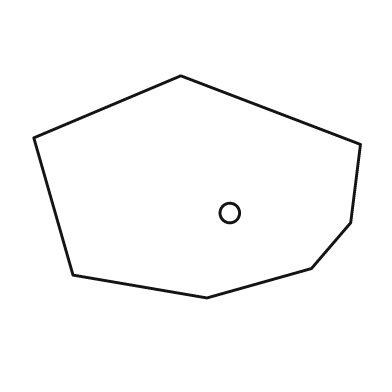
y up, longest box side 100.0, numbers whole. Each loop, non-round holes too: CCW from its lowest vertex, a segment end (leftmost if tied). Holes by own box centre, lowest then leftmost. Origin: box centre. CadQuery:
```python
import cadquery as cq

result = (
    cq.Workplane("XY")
    .moveTo(3.0, -34.0)
    .lineTo(35.0, -25.0)
    .lineTo(47.0, -11.0)
    .lineTo(50.0, 13.0)
    .lineTo(-5.0, 34.0)
    .lineTo(-50.0, 15.0)
    .lineTo(-38.0, -27.0)
    .close()
    .moveTo(10.0, -8.0)
    .circle(3.0)
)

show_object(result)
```